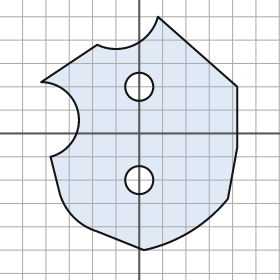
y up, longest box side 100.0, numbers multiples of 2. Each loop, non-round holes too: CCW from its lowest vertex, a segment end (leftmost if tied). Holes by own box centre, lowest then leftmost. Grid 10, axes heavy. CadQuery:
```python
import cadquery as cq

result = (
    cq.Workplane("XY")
    .moveTo(2.0, -50.0)
    .threePointArc((22.0, -42.0), (38.0, -28.0))
    .lineTo(42.0, -6.0)
    .lineTo(42.0, 20.0)
    .lineTo(8.0, 50.0)
    .threePointArc((-2.0, 38.0), (-18.0, 38.0))
    .lineTo(-42.0, 22.0)
    .threePointArc((-26.0, 8.0), (-38.0, -10.0))
    .lineTo(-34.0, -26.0)
    .threePointArc((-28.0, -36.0), (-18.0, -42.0))
    .close()
    .moveTo(0.0, -20.0)
    .circle(6.0)
    .moveTo(0.0, 20.0)
    .circle(6.0)
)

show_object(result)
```